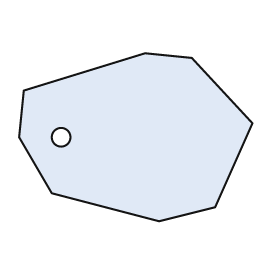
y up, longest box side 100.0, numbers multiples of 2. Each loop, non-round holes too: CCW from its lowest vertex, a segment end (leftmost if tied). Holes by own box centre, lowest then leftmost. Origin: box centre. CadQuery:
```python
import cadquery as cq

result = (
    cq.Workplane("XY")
    .moveTo(10.0, -36.0)
    .lineTo(34.0, -30.0)
    .lineTo(50.0, 6.0)
    .lineTo(24.0, 34.0)
    .lineTo(4.0, 36.0)
    .lineTo(-48.0, 20.0)
    .lineTo(-50.0, 0.0)
    .lineTo(-36.0, -24.0)
    .close()
    .moveTo(-32.0, 0.0)
    .circle(4.0)
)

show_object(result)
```